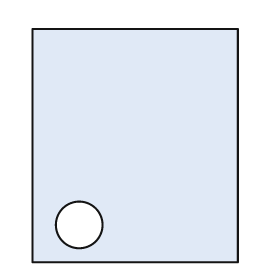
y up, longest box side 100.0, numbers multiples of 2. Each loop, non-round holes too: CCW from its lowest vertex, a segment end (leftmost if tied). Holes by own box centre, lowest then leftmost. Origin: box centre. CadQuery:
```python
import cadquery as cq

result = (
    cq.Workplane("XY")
    .moveTo(-44.0, -50.0)
    .lineTo(44.0, -50.0)
    .lineTo(44.0, 50.0)
    .lineTo(-44.0, 50.0)
    .close()
    .moveTo(-24.0, -34.0)
    .circle(10.0)
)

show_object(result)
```